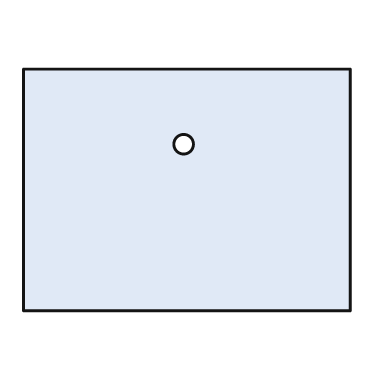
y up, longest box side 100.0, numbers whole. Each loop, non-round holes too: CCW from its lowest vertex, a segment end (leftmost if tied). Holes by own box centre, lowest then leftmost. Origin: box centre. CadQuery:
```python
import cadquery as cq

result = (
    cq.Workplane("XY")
    .moveTo(-50.0, -37.0)
    .lineTo(50.0, -37.0)
    .lineTo(50.0, 37.0)
    .lineTo(-50.0, 37.0)
    .close()
    .moveTo(-1.0, 14.0)
    .circle(3.0)
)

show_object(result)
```